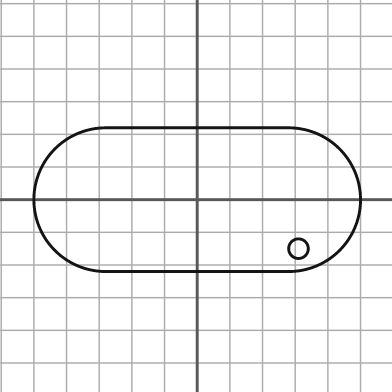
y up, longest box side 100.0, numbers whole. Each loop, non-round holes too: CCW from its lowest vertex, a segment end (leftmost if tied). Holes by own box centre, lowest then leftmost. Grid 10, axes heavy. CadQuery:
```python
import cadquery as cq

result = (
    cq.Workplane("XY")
    .moveTo(-28.0, -22.0)
    .lineTo(28.0, -22.0)
    .threePointArc((50.0, 0.0), (28.0, 22.0))
    .lineTo(-28.0, 22.0)
    .threePointArc((-50.0, 0.0), (-28.0, -22.0))
    .close()
    .moveTo(31.0, -15.0)
    .circle(3.0)
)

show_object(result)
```